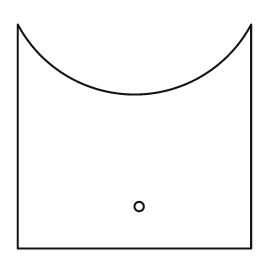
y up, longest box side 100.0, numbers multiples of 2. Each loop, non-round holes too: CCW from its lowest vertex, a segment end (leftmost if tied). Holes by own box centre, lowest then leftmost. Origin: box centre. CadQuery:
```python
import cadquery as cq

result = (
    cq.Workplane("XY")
    .moveTo(-50.0, -48.0)
    .lineTo(50.0, -48.0)
    .lineTo(50.0, 48.0)
    .threePointArc((0.0, 18.0), (-50.0, 48.0))
    .close()
    .moveTo(2.0, -30.0)
    .circle(2.0)
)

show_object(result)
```